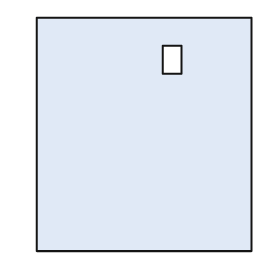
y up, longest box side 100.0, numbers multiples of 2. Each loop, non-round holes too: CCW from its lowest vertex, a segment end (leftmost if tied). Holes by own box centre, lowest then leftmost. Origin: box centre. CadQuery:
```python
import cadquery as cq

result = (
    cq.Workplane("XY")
    .moveTo(-46.0, -50.0)
    .lineTo(46.0, -50.0)
    .lineTo(46.0, 50.0)
    .lineTo(-46.0, 50.0)
    .close()
    .moveTo(8.0, 26.0)
    .lineTo(16.0, 26.0)
    .lineTo(16.0, 38.0)
    .lineTo(8.0, 38.0)
    .close()
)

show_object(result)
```